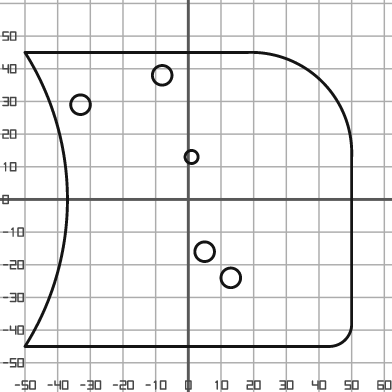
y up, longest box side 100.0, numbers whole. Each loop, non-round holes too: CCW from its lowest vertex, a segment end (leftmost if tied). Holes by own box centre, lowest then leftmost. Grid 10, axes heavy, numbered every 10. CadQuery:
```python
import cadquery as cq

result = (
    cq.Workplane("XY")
    .moveTo(-50.0, -45.0)
    .lineTo(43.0, -45.0)
    .threePointArc((48.0, -43.0), (50.0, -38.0))
    .lineTo(50.0, 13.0)
    .threePointArc((41.0, 36.0), (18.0, 45.0))
    .lineTo(-50.0, 45.0)
    .threePointArc((-37.0, 0.0), (-50.0, -45.0))
    .close()
    .moveTo(13.0, -24.0)
    .circle(3.0)
    .moveTo(5.0, -16.0)
    .circle(3.0)
    .moveTo(1.0, 13.0)
    .circle(2.0)
    .moveTo(-33.0, 29.0)
    .circle(3.0)
    .moveTo(-8.0, 38.0)
    .circle(3.0)
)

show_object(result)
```